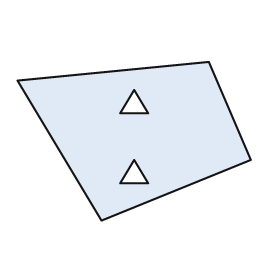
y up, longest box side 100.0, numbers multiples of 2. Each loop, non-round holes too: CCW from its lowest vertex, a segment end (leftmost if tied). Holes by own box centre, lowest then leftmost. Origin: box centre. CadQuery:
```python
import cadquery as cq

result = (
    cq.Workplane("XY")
    .moveTo(-14.0, -34.0)
    .lineTo(50.0, -8.0)
    .lineTo(32.0, 34.0)
    .lineTo(-50.0, 26.0)
    .close()
    .moveTo(-6.0, -18.0)
    .lineTo(6.0, -18.0)
    .lineTo(0.0, -8.0)
    .close()
    .moveTo(-6.0, 12.0)
    .lineTo(6.0, 12.0)
    .lineTo(0.0, 22.0)
    .close()
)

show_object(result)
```